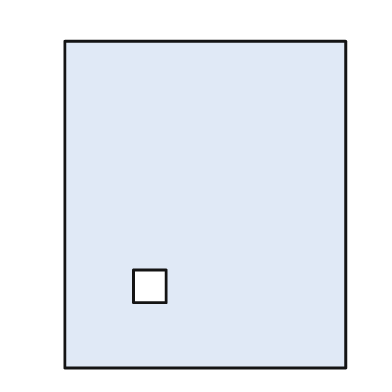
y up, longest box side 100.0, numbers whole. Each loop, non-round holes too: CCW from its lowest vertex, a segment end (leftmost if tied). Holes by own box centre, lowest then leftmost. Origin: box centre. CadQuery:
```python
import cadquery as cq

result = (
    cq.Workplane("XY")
    .moveTo(-43.0, -50.0)
    .lineTo(43.0, -50.0)
    .lineTo(43.0, 50.0)
    .lineTo(-43.0, 50.0)
    .close()
    .moveTo(-22.0, -30.0)
    .lineTo(-12.0, -30.0)
    .lineTo(-12.0, -20.0)
    .lineTo(-22.0, -20.0)
    .close()
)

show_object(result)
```